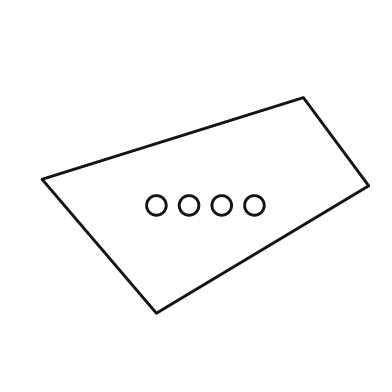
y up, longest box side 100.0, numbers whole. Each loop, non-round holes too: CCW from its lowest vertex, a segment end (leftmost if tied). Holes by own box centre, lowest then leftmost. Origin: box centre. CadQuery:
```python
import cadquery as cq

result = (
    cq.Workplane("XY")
    .moveTo(-15.0, -33.0)
    .lineTo(50.0, 6.0)
    .lineTo(30.0, 33.0)
    .lineTo(-50.0, 8.0)
    .close()
    .moveTo(-15.0, 0.0)
    .circle(3.0)
    .moveTo(-5.0, 0.0)
    .circle(3.0)
    .moveTo(5.0, 0.0)
    .circle(3.0)
    .moveTo(15.0, 0.0)
    .circle(3.0)
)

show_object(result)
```